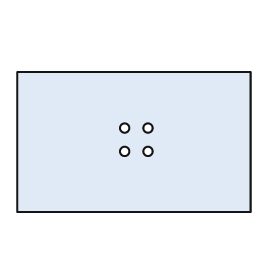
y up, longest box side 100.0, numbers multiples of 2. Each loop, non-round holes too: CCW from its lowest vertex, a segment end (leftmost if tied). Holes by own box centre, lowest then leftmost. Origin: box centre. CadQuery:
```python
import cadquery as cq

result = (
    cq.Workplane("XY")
    .moveTo(-50.0, -30.0)
    .lineTo(50.0, -30.0)
    .lineTo(50.0, 30.0)
    .lineTo(-50.0, 30.0)
    .close()
    .moveTo(-4.0, -4.0)
    .circle(2.0)
    .moveTo(6.0, -4.0)
    .circle(2.0)
    .moveTo(-4.0, 6.0)
    .circle(2.0)
    .moveTo(6.0, 6.0)
    .circle(2.0)
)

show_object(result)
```